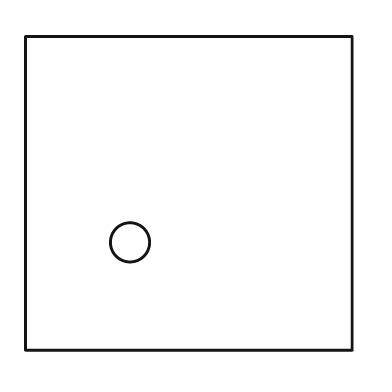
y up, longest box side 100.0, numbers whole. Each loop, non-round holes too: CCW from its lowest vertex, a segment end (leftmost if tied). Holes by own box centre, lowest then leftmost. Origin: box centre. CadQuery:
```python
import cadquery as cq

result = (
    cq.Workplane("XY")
    .moveTo(-50.0, -48.0)
    .lineTo(50.0, -48.0)
    .lineTo(50.0, 48.0)
    .lineTo(-50.0, 48.0)
    .close()
    .moveTo(-18.0, -15.0)
    .circle(6.0)
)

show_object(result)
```